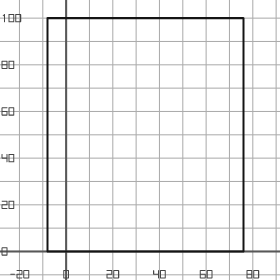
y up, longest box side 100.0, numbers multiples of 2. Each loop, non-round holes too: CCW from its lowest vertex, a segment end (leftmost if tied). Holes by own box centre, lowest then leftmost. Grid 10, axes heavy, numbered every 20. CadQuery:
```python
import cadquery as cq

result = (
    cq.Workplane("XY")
    .moveTo(-8.0, 0.0)
    .lineTo(76.0, 0.0)
    .lineTo(76.0, 100.0)
    .lineTo(-8.0, 100.0)
    .close()
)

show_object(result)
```